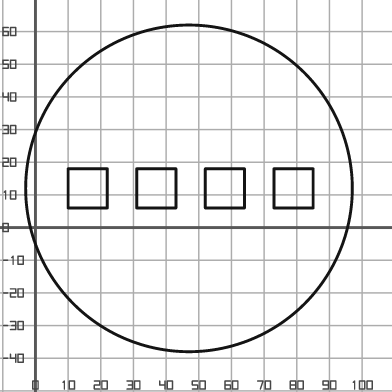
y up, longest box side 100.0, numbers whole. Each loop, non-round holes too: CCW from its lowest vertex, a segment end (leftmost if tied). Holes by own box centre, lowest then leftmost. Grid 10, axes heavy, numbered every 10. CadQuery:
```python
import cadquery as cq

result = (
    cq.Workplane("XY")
    .moveTo(47.0, 12.0)
    .circle(50.0)
    .moveTo(10.0, 6.0)
    .lineTo(22.0, 6.0)
    .lineTo(22.0, 18.0)
    .lineTo(10.0, 18.0)
    .close()
    .moveTo(31.0, 6.0)
    .lineTo(43.0, 6.0)
    .lineTo(43.0, 18.0)
    .lineTo(31.0, 18.0)
    .close()
    .moveTo(52.0, 6.0)
    .lineTo(64.0, 6.0)
    .lineTo(64.0, 18.0)
    .lineTo(52.0, 18.0)
    .close()
    .moveTo(73.0, 6.0)
    .lineTo(85.0, 6.0)
    .lineTo(85.0, 18.0)
    .lineTo(73.0, 18.0)
    .close()
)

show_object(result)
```